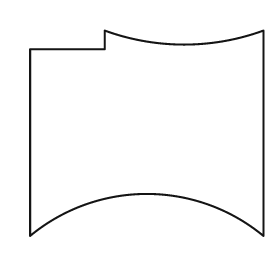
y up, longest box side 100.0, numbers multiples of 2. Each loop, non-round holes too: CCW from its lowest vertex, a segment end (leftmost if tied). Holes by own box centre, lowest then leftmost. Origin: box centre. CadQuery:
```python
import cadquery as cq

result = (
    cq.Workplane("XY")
    .moveTo(-50.0, -44.0)
    .threePointArc((0.0, -26.0), (50.0, -44.0))
    .lineTo(50.0, 44.0)
    .threePointArc((16.0, 38.0), (-18.0, 44.0))
    .lineTo(-18.0, 36.0)
    .lineTo(-50.0, 36.0)
    .close()
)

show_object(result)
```